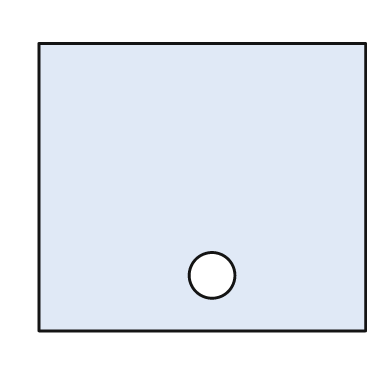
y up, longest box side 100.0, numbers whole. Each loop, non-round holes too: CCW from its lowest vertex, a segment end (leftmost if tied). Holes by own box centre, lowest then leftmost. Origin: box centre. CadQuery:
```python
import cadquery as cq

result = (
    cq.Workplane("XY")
    .moveTo(-50.0, -44.0)
    .lineTo(50.0, -44.0)
    .lineTo(50.0, 44.0)
    .lineTo(-50.0, 44.0)
    .close()
    .moveTo(3.0, -27.0)
    .circle(7.0)
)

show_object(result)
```